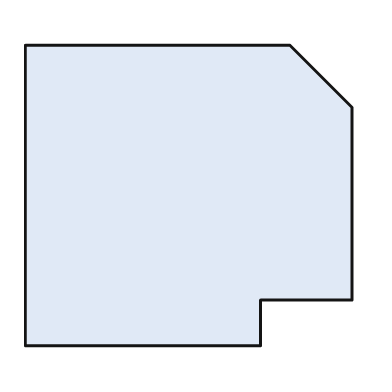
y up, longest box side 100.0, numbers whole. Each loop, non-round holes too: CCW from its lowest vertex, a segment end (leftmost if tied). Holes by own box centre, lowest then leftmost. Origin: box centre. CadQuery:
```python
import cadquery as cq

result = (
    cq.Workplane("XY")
    .moveTo(-50.0, -46.0)
    .lineTo(22.0, -46.0)
    .lineTo(22.0, -32.0)
    .lineTo(50.0, -32.0)
    .lineTo(50.0, 27.0)
    .lineTo(31.0, 46.0)
    .lineTo(-50.0, 46.0)
    .close()
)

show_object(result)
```